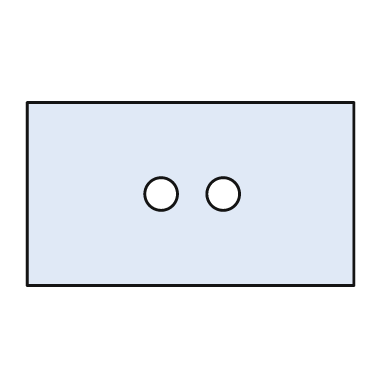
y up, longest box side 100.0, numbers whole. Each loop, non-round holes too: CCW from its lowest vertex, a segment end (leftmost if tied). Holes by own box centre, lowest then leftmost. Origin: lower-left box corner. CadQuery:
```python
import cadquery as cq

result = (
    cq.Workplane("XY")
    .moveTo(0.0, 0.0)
    .lineTo(100.0, 0.0)
    .lineTo(100.0, 56.0)
    .lineTo(0.0, 56.0)
    .close()
    .moveTo(41.0, 28.0)
    .circle(5.0)
    .moveTo(60.0, 28.0)
    .circle(5.0)
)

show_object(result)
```